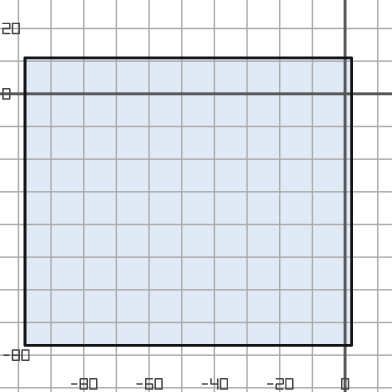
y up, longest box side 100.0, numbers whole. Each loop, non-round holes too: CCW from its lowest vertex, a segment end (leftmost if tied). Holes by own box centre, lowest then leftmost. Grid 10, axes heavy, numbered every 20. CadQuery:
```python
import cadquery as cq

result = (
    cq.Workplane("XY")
    .moveTo(-98.0, -77.0)
    .lineTo(2.0, -77.0)
    .lineTo(2.0, 11.0)
    .lineTo(-98.0, 11.0)
    .close()
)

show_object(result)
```